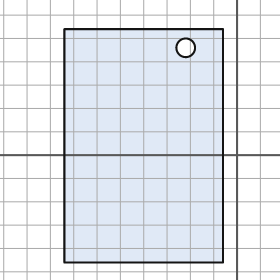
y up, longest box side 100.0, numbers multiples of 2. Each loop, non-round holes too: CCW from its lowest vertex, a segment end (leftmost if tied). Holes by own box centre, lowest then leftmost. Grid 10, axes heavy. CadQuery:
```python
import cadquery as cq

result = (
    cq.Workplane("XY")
    .moveTo(-74.0, -46.0)
    .lineTo(-6.0, -46.0)
    .lineTo(-6.0, 54.0)
    .lineTo(-74.0, 54.0)
    .close()
    .moveTo(-22.0, 46.0)
    .circle(4.0)
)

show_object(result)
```